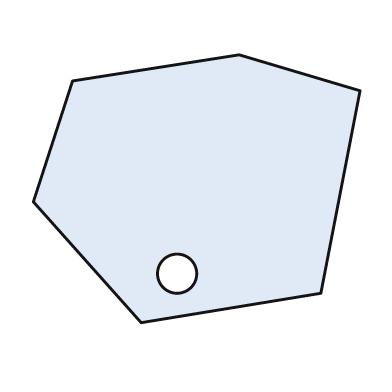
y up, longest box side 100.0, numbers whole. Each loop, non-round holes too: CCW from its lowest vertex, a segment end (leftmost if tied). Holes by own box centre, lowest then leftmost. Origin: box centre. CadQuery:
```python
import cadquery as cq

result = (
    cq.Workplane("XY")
    .moveTo(-17.0, -41.0)
    .lineTo(38.0, -32.0)
    .lineTo(50.0, 30.0)
    .lineTo(13.0, 41.0)
    .lineTo(-38.0, 33.0)
    .lineTo(-50.0, -4.0)
    .close()
    .moveTo(-6.0, -26.0)
    .circle(6.0)
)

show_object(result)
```